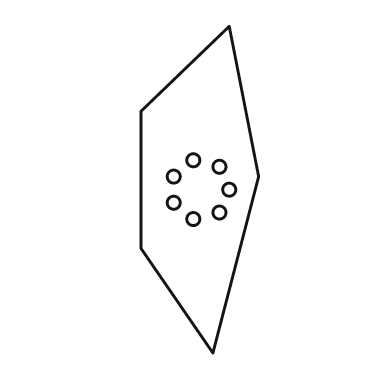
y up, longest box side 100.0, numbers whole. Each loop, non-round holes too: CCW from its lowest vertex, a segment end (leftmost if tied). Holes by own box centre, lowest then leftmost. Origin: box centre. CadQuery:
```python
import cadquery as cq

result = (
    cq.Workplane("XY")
    .moveTo(4.0, -50.0)
    .lineTo(18.0, 4.0)
    .lineTo(9.0, 50.0)
    .lineTo(-18.0, 24.0)
    .lineTo(-18.0, -18.0)
    .close()
    .moveTo(-2.0, -9.0)
    .circle(2.0)
    .moveTo(6.0, -7.0)
    .circle(2.0)
    .moveTo(-8.0, -4.0)
    .circle(2.0)
    .moveTo(9.0, 0.0)
    .circle(2.0)
    .moveTo(-8.0, 4.0)
    .circle(2.0)
    .moveTo(6.0, 7.0)
    .circle(2.0)
    .moveTo(-2.0, 9.0)
    .circle(2.0)
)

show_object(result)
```